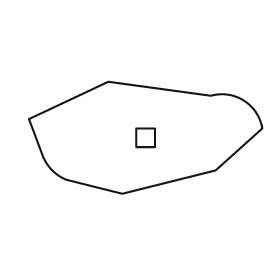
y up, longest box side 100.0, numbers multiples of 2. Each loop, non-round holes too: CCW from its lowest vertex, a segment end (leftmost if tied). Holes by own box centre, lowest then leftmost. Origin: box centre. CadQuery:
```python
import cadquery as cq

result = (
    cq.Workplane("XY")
    .moveTo(-10.0, -24.0)
    .lineTo(30.0, -14.0)
    .lineTo(50.0, 4.0)
    .threePointArc((42.0, 16.0), (28.0, 18.0))
    .lineTo(-16.0, 24.0)
    .lineTo(-50.0, 8.0)
    .lineTo(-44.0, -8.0)
    .threePointArc((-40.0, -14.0), (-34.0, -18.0))
    .close()
    .moveTo(-4.0, -4.0)
    .lineTo(4.0, -4.0)
    .lineTo(4.0, 4.0)
    .lineTo(-4.0, 4.0)
    .close()
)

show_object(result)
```